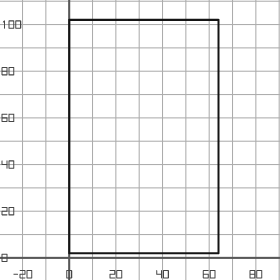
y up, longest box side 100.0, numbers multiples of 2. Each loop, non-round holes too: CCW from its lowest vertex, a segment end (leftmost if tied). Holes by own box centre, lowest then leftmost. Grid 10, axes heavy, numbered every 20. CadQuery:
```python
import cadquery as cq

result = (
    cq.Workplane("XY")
    .moveTo(0.0, 2.0)
    .lineTo(64.0, 2.0)
    .lineTo(64.0, 102.0)
    .lineTo(0.0, 102.0)
    .close()
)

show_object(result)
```